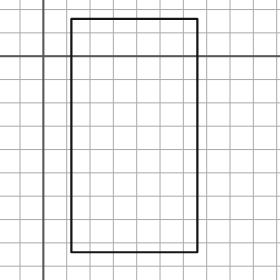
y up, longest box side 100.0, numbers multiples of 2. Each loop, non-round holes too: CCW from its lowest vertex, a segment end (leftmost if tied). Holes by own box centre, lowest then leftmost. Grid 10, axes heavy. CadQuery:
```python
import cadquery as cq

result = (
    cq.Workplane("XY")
    .moveTo(12.0, -84.0)
    .lineTo(66.0, -84.0)
    .lineTo(66.0, 16.0)
    .lineTo(12.0, 16.0)
    .close()
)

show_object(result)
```